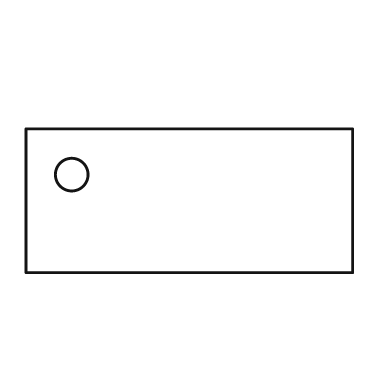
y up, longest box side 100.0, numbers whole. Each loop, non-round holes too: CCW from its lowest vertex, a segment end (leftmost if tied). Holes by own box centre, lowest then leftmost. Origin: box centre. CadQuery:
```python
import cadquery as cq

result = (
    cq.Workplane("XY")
    .moveTo(-50.0, -22.0)
    .lineTo(50.0, -22.0)
    .lineTo(50.0, 22.0)
    .lineTo(-50.0, 22.0)
    .close()
    .moveTo(-36.0, 8.0)
    .circle(5.0)
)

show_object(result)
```